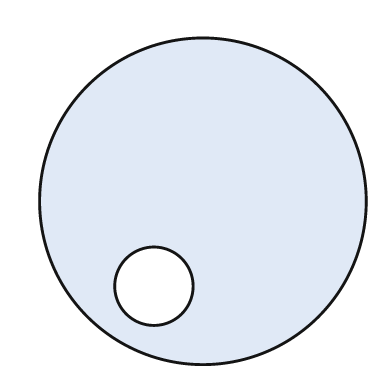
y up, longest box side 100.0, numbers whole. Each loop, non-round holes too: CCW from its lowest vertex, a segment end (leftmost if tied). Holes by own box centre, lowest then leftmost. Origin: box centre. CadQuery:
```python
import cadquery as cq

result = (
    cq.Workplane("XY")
    .moveTo(0.0, 0.0)
    .circle(50.0)
    .moveTo(-15.0, -26.0)
    .circle(12.0)
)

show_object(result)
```